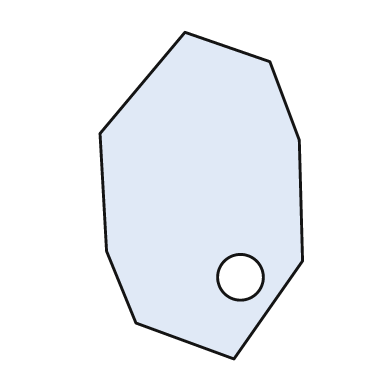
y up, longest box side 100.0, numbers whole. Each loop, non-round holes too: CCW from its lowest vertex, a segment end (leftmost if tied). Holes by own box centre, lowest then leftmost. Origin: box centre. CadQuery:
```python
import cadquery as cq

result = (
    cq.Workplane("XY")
    .moveTo(10.0, -50.0)
    .lineTo(31.0, -20.0)
    .lineTo(30.0, 17.0)
    .lineTo(21.0, 41.0)
    .lineTo(-5.0, 50.0)
    .lineTo(-31.0, 19.0)
    .lineTo(-29.0, -17.0)
    .lineTo(-20.0, -39.0)
    .close()
    .moveTo(12.0, -25.0)
    .circle(7.0)
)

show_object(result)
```